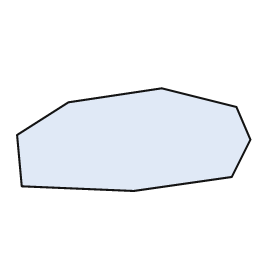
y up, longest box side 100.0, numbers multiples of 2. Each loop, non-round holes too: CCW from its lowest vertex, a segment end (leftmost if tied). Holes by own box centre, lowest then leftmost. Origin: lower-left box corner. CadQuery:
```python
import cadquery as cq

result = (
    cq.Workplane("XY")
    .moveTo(50.0, 0.0)
    .lineTo(92.0, 6.0)
    .lineTo(100.0, 22.0)
    .lineTo(94.0, 36.0)
    .lineTo(62.0, 44.0)
    .lineTo(22.0, 38.0)
    .lineTo(0.0, 24.0)
    .lineTo(2.0, 2.0)
    .close()
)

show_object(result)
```